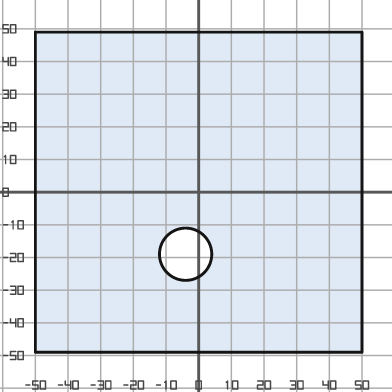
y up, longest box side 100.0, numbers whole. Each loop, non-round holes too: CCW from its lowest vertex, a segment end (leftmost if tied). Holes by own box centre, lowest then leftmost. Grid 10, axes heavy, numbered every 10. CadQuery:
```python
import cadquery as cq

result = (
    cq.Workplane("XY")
    .moveTo(-50.0, -49.0)
    .lineTo(50.0, -49.0)
    .lineTo(50.0, 49.0)
    .lineTo(-50.0, 49.0)
    .close()
    .moveTo(-4.0, -19.0)
    .circle(8.0)
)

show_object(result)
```